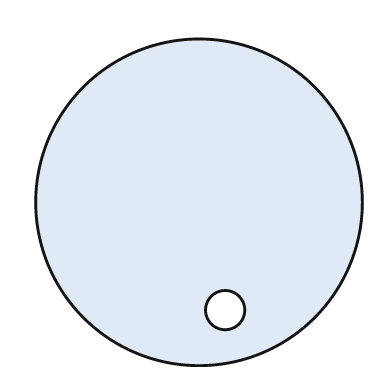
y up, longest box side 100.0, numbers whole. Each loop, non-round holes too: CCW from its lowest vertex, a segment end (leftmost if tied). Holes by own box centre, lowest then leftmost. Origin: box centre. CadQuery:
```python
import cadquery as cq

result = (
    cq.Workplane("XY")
    .moveTo(0.0, 0.0)
    .circle(50.0)
    .moveTo(8.0, -33.0)
    .circle(6.0)
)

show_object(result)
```